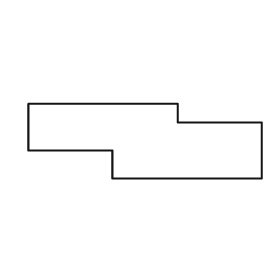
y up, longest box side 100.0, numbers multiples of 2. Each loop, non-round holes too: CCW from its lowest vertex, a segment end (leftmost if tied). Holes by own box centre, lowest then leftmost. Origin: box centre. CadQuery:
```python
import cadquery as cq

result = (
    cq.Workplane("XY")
    .moveTo(-14.0, -16.0)
    .lineTo(50.0, -16.0)
    .lineTo(50.0, 8.0)
    .lineTo(14.0, 8.0)
    .lineTo(14.0, 16.0)
    .lineTo(-50.0, 16.0)
    .lineTo(-50.0, -4.0)
    .lineTo(-14.0, -4.0)
    .close()
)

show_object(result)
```